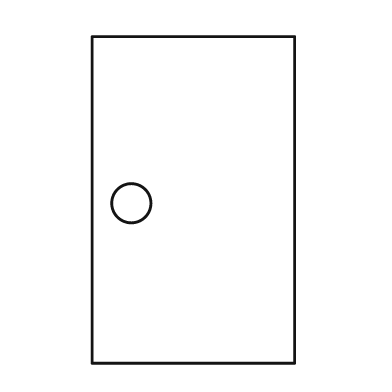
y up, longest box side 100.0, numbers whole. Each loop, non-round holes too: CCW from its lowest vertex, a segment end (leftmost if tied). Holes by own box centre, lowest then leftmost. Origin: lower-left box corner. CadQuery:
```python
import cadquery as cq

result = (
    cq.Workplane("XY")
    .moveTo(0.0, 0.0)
    .lineTo(62.0, 0.0)
    .lineTo(62.0, 100.0)
    .lineTo(0.0, 100.0)
    .close()
    .moveTo(12.0, 49.0)
    .circle(6.0)
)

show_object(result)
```